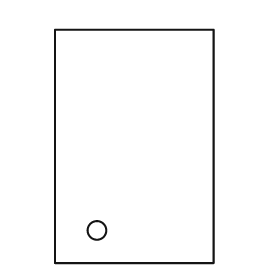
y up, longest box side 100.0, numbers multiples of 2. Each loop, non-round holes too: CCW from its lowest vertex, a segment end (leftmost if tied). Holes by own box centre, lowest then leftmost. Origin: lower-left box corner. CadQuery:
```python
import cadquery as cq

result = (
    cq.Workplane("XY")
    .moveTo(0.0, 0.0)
    .lineTo(68.0, 0.0)
    .lineTo(68.0, 100.0)
    .lineTo(0.0, 100.0)
    .close()
    .moveTo(18.0, 14.0)
    .circle(4.0)
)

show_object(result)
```